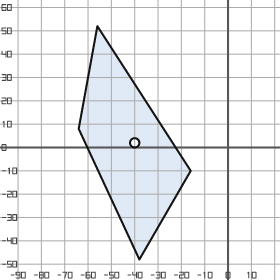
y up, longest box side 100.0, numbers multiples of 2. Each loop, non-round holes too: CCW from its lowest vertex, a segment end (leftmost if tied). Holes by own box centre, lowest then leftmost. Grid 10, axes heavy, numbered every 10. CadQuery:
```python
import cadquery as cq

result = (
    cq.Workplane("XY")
    .moveTo(-38.0, -48.0)
    .lineTo(-16.0, -10.0)
    .lineTo(-56.0, 52.0)
    .lineTo(-64.0, 8.0)
    .close()
    .moveTo(-40.0, 2.0)
    .circle(2.0)
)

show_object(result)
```